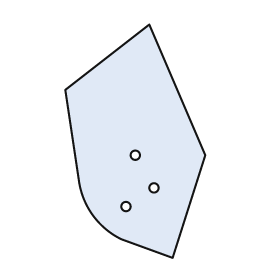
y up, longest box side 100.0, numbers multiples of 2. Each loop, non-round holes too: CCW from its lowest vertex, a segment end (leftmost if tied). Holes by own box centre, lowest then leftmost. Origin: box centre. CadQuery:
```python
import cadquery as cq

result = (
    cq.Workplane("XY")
    .moveTo(16.0, -50.0)
    .lineTo(30.0, -6.0)
    .lineTo(6.0, 50.0)
    .lineTo(-30.0, 22.0)
    .lineTo(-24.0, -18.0)
    .threePointArc((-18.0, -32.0), (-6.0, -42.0))
    .close()
    .moveTo(-4.0, -28.0)
    .circle(2.0)
    .moveTo(8.0, -20.0)
    .circle(2.0)
    .moveTo(0.0, -6.0)
    .circle(2.0)
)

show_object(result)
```